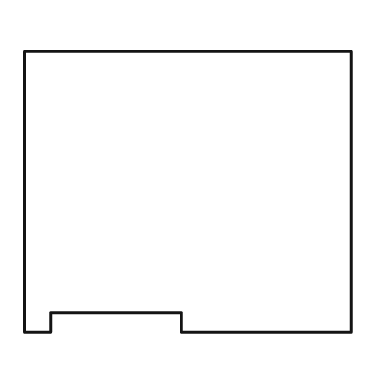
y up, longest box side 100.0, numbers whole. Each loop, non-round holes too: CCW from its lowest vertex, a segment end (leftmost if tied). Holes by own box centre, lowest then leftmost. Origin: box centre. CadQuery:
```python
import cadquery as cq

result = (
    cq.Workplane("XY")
    .moveTo(-50.0, -43.0)
    .lineTo(-42.0, -43.0)
    .lineTo(-42.0, -37.0)
    .lineTo(-2.0, -37.0)
    .lineTo(-2.0, -43.0)
    .lineTo(50.0, -43.0)
    .lineTo(50.0, 43.0)
    .lineTo(-50.0, 43.0)
    .close()
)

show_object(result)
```